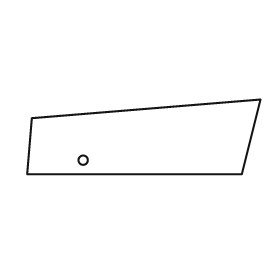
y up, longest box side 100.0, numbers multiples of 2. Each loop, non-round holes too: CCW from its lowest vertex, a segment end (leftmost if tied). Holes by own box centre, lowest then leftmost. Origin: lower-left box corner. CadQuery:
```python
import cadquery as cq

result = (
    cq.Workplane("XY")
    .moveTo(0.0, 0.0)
    .lineTo(92.0, 0.0)
    .lineTo(100.0, 32.0)
    .lineTo(2.0, 24.0)
    .close()
    .moveTo(24.0, 6.0)
    .circle(2.0)
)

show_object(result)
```